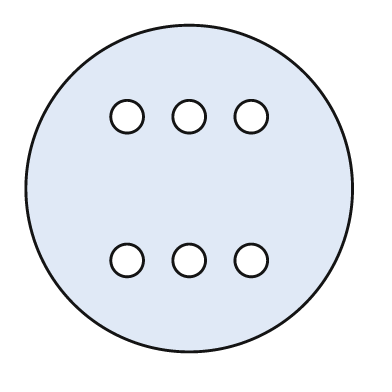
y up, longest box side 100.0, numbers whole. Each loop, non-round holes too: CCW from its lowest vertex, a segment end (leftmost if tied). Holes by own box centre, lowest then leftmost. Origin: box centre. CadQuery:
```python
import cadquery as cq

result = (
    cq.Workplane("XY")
    .moveTo(0.0, 0.0)
    .circle(50.0)
    .moveTo(-19.0, -22.0)
    .circle(5.0)
    .moveTo(0.0, -22.0)
    .circle(5.0)
    .moveTo(19.0, -22.0)
    .circle(5.0)
    .moveTo(-19.0, 22.0)
    .circle(5.0)
    .moveTo(0.0, 22.0)
    .circle(5.0)
    .moveTo(19.0, 22.0)
    .circle(5.0)
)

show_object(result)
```